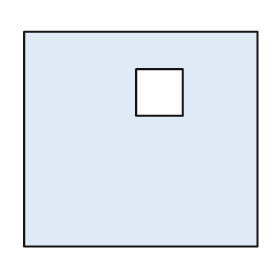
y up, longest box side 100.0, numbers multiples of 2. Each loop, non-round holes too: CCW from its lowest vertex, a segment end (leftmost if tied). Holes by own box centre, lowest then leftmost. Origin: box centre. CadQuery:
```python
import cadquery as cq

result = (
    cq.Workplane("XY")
    .moveTo(-50.0, -46.0)
    .lineTo(50.0, -46.0)
    .lineTo(50.0, 46.0)
    .lineTo(-50.0, 46.0)
    .close()
    .moveTo(-2.0, 10.0)
    .lineTo(18.0, 10.0)
    .lineTo(18.0, 30.0)
    .lineTo(-2.0, 30.0)
    .close()
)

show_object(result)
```